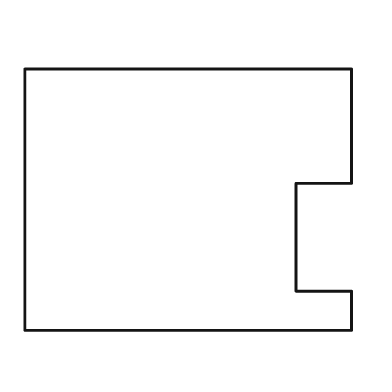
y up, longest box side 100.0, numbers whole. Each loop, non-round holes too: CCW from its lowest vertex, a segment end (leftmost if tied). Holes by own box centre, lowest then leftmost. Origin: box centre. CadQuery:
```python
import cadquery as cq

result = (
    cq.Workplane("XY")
    .moveTo(-50.0, -40.0)
    .lineTo(50.0, -40.0)
    .lineTo(50.0, -28.0)
    .lineTo(33.0, -28.0)
    .lineTo(33.0, 5.0)
    .lineTo(50.0, 5.0)
    .lineTo(50.0, 40.0)
    .lineTo(-50.0, 40.0)
    .close()
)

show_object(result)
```